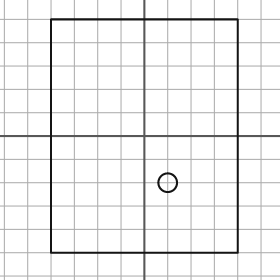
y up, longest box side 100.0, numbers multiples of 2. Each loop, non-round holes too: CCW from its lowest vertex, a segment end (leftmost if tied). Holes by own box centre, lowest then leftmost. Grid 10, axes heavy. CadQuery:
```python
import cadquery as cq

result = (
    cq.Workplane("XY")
    .moveTo(-40.0, -50.0)
    .lineTo(40.0, -50.0)
    .lineTo(40.0, 50.0)
    .lineTo(-40.0, 50.0)
    .close()
    .moveTo(10.0, -20.0)
    .circle(4.0)
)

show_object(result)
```